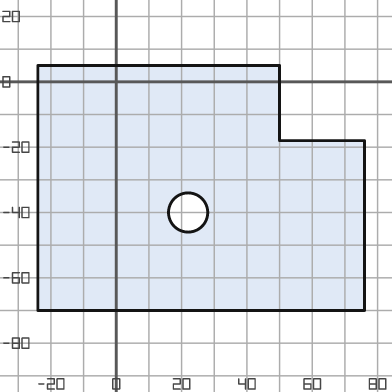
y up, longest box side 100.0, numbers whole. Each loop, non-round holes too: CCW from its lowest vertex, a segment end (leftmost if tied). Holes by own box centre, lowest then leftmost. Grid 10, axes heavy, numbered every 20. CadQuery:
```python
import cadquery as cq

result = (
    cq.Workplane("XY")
    .moveTo(-24.0, -70.0)
    .lineTo(76.0, -70.0)
    .lineTo(76.0, -18.0)
    .lineTo(50.0, -18.0)
    .lineTo(50.0, 5.0)
    .lineTo(-24.0, 5.0)
    .close()
    .moveTo(22.0, -40.0)
    .circle(6.0)
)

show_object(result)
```